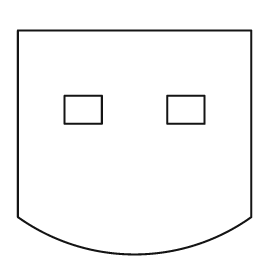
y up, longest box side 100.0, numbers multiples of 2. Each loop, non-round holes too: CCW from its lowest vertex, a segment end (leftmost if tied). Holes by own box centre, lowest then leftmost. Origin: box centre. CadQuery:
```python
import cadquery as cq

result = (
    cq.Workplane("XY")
    .moveTo(-50.0, -32.0)
    .threePointArc((0.0, -48.0), (50.0, -32.0))
    .lineTo(50.0, 48.0)
    .lineTo(-50.0, 48.0)
    .close()
    .moveTo(-30.0, 8.0)
    .lineTo(-14.0, 8.0)
    .lineTo(-14.0, 20.0)
    .lineTo(-30.0, 20.0)
    .close()
    .moveTo(14.0, 8.0)
    .lineTo(30.0, 8.0)
    .lineTo(30.0, 20.0)
    .lineTo(14.0, 20.0)
    .close()
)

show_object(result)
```